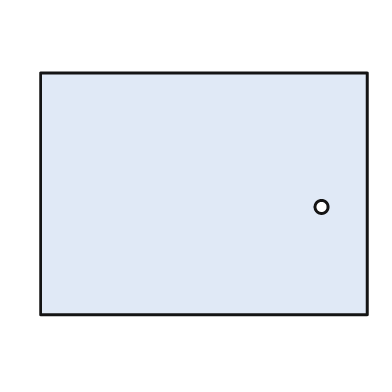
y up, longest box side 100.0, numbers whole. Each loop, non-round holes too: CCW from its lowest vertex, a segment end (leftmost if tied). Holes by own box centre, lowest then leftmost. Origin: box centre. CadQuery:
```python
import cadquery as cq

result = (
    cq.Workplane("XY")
    .moveTo(-50.0, -37.0)
    .lineTo(50.0, -37.0)
    .lineTo(50.0, 37.0)
    .lineTo(-50.0, 37.0)
    .close()
    .moveTo(36.0, -4.0)
    .circle(2.0)
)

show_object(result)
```